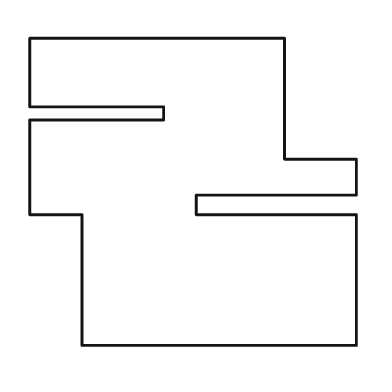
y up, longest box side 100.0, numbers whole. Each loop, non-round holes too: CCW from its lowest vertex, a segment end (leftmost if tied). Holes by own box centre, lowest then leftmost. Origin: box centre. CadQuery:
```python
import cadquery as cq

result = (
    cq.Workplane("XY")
    .moveTo(-34.0, -47.0)
    .lineTo(50.0, -47.0)
    .lineTo(50.0, -7.0)
    .lineTo(1.0, -7.0)
    .lineTo(1.0, -1.0)
    .lineTo(50.0, -1.0)
    .lineTo(50.0, 10.0)
    .lineTo(28.0, 10.0)
    .lineTo(28.0, 47.0)
    .lineTo(-50.0, 47.0)
    .lineTo(-50.0, 26.0)
    .lineTo(-9.0, 26.0)
    .lineTo(-9.0, 22.0)
    .lineTo(-50.0, 22.0)
    .lineTo(-50.0, -7.0)
    .lineTo(-34.0, -7.0)
    .close()
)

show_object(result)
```